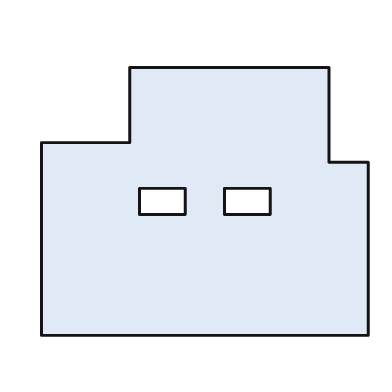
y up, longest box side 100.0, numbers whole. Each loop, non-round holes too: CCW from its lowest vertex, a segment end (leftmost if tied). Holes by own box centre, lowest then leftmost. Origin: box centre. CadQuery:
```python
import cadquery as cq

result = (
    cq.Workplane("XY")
    .moveTo(-50.0, -41.0)
    .lineTo(50.0, -41.0)
    .lineTo(50.0, 12.0)
    .lineTo(38.0, 12.0)
    .lineTo(38.0, 41.0)
    .lineTo(-23.0, 41.0)
    .lineTo(-23.0, 18.0)
    .lineTo(-50.0, 18.0)
    .close()
    .moveTo(-20.0, -4.0)
    .lineTo(-6.0, -4.0)
    .lineTo(-6.0, 4.0)
    .lineTo(-20.0, 4.0)
    .close()
    .moveTo(6.0, -4.0)
    .lineTo(20.0, -4.0)
    .lineTo(20.0, 4.0)
    .lineTo(6.0, 4.0)
    .close()
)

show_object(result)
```